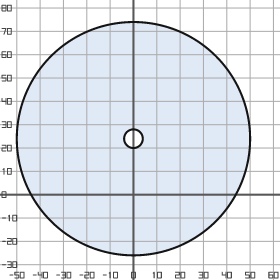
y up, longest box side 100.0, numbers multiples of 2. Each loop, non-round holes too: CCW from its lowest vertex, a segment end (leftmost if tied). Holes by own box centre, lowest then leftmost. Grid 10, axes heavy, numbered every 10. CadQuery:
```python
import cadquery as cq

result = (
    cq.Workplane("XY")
    .moveTo(0.0, 24.0)
    .circle(50.0)
    .moveTo(0.0, 24.0)
    .circle(4.0)
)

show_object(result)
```